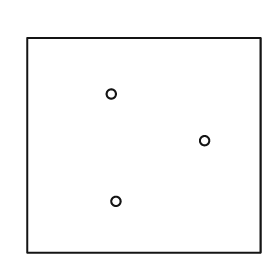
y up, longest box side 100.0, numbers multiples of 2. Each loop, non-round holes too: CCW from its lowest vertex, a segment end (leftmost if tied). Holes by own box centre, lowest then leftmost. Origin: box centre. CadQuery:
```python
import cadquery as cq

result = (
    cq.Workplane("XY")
    .moveTo(-50.0, -46.0)
    .lineTo(50.0, -46.0)
    .lineTo(50.0, 46.0)
    .lineTo(-50.0, 46.0)
    .close()
    .moveTo(-12.0, -24.0)
    .circle(2.0)
    .moveTo(26.0, 2.0)
    .circle(2.0)
    .moveTo(-14.0, 22.0)
    .circle(2.0)
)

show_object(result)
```